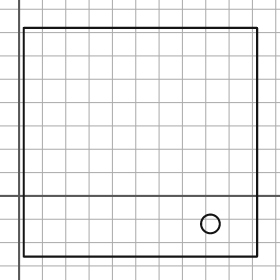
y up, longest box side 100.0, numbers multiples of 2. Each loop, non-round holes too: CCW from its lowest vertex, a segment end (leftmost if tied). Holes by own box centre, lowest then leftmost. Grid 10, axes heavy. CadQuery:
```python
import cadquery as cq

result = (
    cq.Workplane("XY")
    .moveTo(2.0, -26.0)
    .lineTo(102.0, -26.0)
    .lineTo(102.0, 72.0)
    .lineTo(2.0, 72.0)
    .close()
    .moveTo(82.0, -12.0)
    .circle(4.0)
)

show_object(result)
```